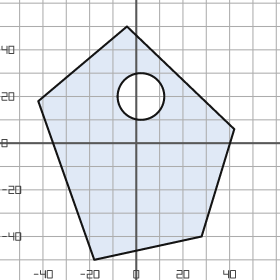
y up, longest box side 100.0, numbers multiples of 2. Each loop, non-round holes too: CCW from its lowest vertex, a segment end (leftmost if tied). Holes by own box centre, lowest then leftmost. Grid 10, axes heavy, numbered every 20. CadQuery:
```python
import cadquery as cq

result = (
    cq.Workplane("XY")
    .moveTo(-18.0, -50.0)
    .lineTo(28.0, -40.0)
    .lineTo(42.0, 6.0)
    .lineTo(-4.0, 50.0)
    .lineTo(-42.0, 18.0)
    .close()
    .moveTo(2.0, 20.0)
    .circle(10.0)
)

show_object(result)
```